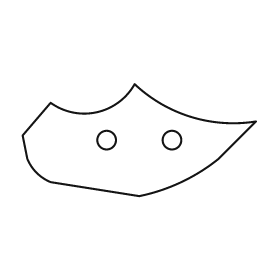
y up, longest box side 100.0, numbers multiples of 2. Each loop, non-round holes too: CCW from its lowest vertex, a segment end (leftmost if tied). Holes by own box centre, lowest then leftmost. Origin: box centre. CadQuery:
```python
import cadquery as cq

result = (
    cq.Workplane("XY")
    .moveTo(0.0, -24.0)
    .threePointArc((18.0, -18.0), (34.0, -8.0))
    .lineTo(50.0, 8.0)
    .threePointArc((22.0, 10.0), (-2.0, 24.0))
    .threePointArc((-18.0, 12.0), (-38.0, 16.0))
    .lineTo(-50.0, 2.0)
    .lineTo(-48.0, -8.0)
    .threePointArc((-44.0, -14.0), (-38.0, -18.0))
    .close()
    .moveTo(-14.0, 0.0)
    .circle(4.0)
    .moveTo(14.0, 0.0)
    .circle(4.0)
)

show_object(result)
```